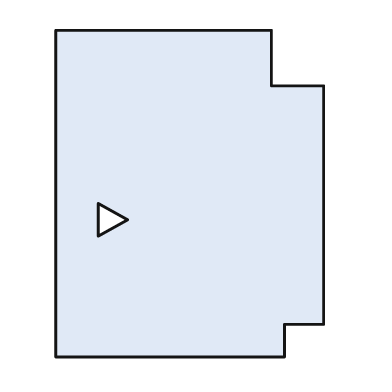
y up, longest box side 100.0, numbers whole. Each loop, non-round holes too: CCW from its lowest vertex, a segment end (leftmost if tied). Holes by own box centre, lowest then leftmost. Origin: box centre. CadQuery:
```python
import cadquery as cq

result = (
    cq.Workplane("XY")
    .moveTo(-41.0, -50.0)
    .lineTo(29.0, -50.0)
    .lineTo(29.0, -40.0)
    .lineTo(41.0, -40.0)
    .lineTo(41.0, 33.0)
    .lineTo(25.0, 33.0)
    .lineTo(25.0, 50.0)
    .lineTo(-41.0, 50.0)
    .close()
    .moveTo(-28.0, -13.0)
    .lineTo(-19.0, -8.0)
    .lineTo(-28.0, -3.0)
    .close()
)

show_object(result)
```